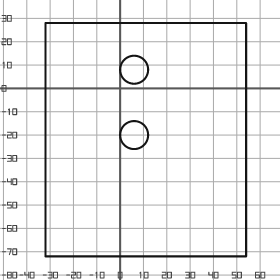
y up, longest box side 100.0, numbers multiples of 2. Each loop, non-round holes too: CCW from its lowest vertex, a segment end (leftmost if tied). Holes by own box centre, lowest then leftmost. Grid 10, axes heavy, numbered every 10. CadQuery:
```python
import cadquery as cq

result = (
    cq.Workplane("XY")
    .moveTo(-32.0, -72.0)
    .lineTo(54.0, -72.0)
    .lineTo(54.0, 28.0)
    .lineTo(-32.0, 28.0)
    .close()
    .moveTo(6.0, -20.0)
    .circle(6.0)
    .moveTo(6.0, 8.0)
    .circle(6.0)
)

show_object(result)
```